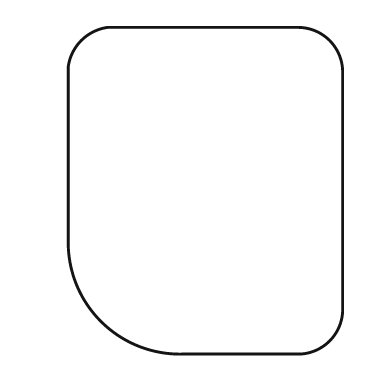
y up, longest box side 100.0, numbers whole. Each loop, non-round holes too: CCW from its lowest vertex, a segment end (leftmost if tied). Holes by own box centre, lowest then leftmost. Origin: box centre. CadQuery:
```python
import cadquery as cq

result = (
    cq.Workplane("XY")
    .moveTo(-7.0, -50.0)
    .lineTo(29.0, -50.0)
    .threePointArc((38.0, -46.0), (42.0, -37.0))
    .lineTo(42.0, 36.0)
    .threePointArc((38.0, 46.0), (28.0, 50.0))
    .lineTo(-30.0, 50.0)
    .threePointArc((-38.0, 46.0), (-42.0, 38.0))
    .lineTo(-42.0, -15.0)
    .threePointArc((-32.0, -40.0), (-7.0, -50.0))
    .close()
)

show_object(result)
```